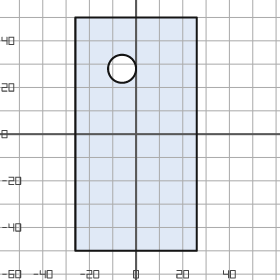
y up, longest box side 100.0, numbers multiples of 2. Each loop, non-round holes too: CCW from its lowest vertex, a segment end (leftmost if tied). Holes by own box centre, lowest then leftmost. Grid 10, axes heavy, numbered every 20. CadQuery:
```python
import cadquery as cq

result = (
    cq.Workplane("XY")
    .moveTo(-26.0, -50.0)
    .lineTo(26.0, -50.0)
    .lineTo(26.0, 50.0)
    .lineTo(-26.0, 50.0)
    .close()
    .moveTo(-6.0, 28.0)
    .circle(6.0)
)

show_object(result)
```